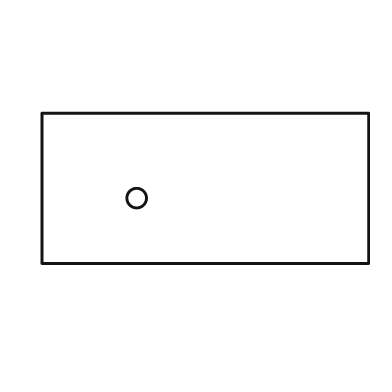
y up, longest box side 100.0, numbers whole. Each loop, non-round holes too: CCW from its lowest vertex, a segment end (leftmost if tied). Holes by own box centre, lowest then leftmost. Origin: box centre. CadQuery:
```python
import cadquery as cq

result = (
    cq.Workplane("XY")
    .moveTo(-50.0, -23.0)
    .lineTo(50.0, -23.0)
    .lineTo(50.0, 23.0)
    .lineTo(-50.0, 23.0)
    .close()
    .moveTo(-21.0, -3.0)
    .circle(3.0)
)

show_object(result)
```